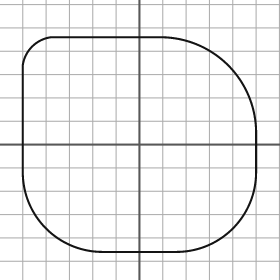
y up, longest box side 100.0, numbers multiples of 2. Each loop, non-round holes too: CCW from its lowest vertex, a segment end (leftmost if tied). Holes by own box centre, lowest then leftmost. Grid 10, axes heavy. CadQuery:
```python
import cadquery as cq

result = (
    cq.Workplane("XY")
    .moveTo(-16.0, -46.0)
    .lineTo(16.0, -46.0)
    .threePointArc((40.0, -36.0), (50.0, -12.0))
    .lineTo(50.0, 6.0)
    .threePointArc((38.0, 34.0), (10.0, 46.0))
    .lineTo(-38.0, 46.0)
    .threePointArc((-46.0, 42.0), (-50.0, 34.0))
    .lineTo(-50.0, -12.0)
    .threePointArc((-40.0, -36.0), (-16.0, -46.0))
    .close()
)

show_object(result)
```